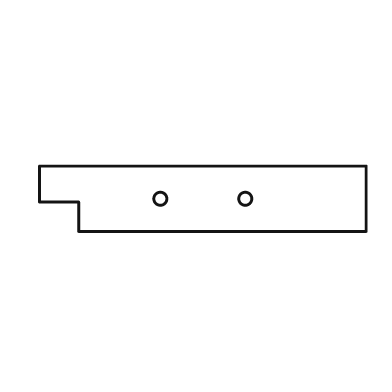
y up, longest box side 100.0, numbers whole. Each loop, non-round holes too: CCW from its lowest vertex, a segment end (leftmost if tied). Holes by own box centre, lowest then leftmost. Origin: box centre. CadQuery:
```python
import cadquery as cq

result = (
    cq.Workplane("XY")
    .moveTo(-38.0, -10.0)
    .lineTo(50.0, -10.0)
    .lineTo(50.0, 10.0)
    .lineTo(-50.0, 10.0)
    .lineTo(-50.0, -1.0)
    .lineTo(-38.0, -1.0)
    .close()
    .moveTo(-13.0, 0.0)
    .circle(2.0)
    .moveTo(13.0, 0.0)
    .circle(2.0)
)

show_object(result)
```